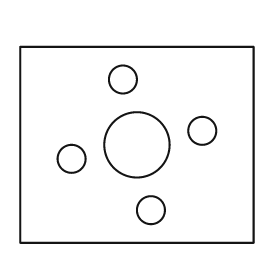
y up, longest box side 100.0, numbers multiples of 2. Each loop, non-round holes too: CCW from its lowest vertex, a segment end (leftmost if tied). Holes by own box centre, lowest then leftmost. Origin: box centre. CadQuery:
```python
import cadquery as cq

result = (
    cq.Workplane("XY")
    .moveTo(-50.0, -42.0)
    .lineTo(50.0, -42.0)
    .lineTo(50.0, 42.0)
    .lineTo(-50.0, 42.0)
    .close()
    .moveTo(6.0, -28.0)
    .circle(6.0)
    .moveTo(-28.0, -6.0)
    .circle(6.0)
    .moveTo(0.0, 0.0)
    .circle(14.0)
    .moveTo(28.0, 6.0)
    .circle(6.0)
    .moveTo(-6.0, 28.0)
    .circle(6.0)
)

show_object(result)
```